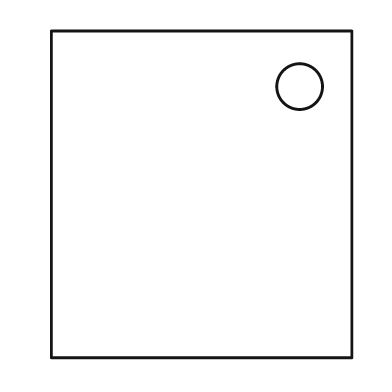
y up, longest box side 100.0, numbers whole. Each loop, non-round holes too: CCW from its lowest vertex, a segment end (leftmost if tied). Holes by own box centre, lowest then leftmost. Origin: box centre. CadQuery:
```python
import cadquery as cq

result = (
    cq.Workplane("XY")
    .moveTo(-46.0, -50.0)
    .lineTo(46.0, -50.0)
    .lineTo(46.0, 50.0)
    .lineTo(-46.0, 50.0)
    .close()
    .moveTo(30.0, 33.0)
    .circle(7.0)
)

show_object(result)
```